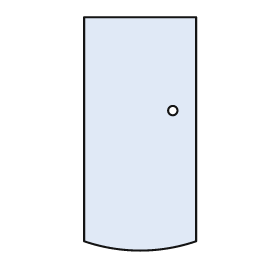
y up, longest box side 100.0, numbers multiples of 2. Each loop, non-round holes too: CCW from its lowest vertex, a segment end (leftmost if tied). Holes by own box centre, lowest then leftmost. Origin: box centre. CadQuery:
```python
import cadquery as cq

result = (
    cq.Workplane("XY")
    .moveTo(-24.0, -46.0)
    .threePointArc((0.0, -50.0), (24.0, -46.0))
    .lineTo(24.0, 50.0)
    .lineTo(-24.0, 50.0)
    .close()
    .moveTo(14.0, 10.0)
    .circle(2.0)
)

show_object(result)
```